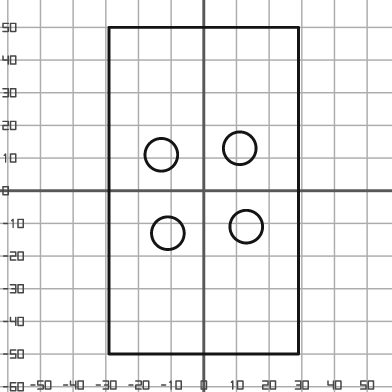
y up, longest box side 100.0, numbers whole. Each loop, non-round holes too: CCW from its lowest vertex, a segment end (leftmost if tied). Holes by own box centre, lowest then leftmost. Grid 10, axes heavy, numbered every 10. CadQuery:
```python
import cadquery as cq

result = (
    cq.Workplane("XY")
    .moveTo(-29.0, -50.0)
    .lineTo(29.0, -50.0)
    .lineTo(29.0, 50.0)
    .lineTo(-29.0, 50.0)
    .close()
    .moveTo(-11.0, -13.0)
    .circle(5.0)
    .moveTo(13.0, -11.0)
    .circle(5.0)
    .moveTo(-13.0, 11.0)
    .circle(5.0)
    .moveTo(11.0, 13.0)
    .circle(5.0)
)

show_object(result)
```